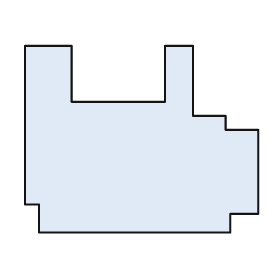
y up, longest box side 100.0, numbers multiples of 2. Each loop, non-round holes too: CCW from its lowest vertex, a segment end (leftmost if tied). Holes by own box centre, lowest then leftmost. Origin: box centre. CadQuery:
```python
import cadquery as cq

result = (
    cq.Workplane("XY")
    .moveTo(-44.0, -40.0)
    .lineTo(38.0, -40.0)
    .lineTo(38.0, -32.0)
    .lineTo(50.0, -32.0)
    .lineTo(50.0, 4.0)
    .lineTo(36.0, 4.0)
    .lineTo(36.0, 10.0)
    .lineTo(22.0, 10.0)
    .lineTo(22.0, 40.0)
    .lineTo(10.0, 40.0)
    .lineTo(10.0, 16.0)
    .lineTo(-30.0, 16.0)
    .lineTo(-30.0, 40.0)
    .lineTo(-50.0, 40.0)
    .lineTo(-50.0, -28.0)
    .lineTo(-44.0, -28.0)
    .close()
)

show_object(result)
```